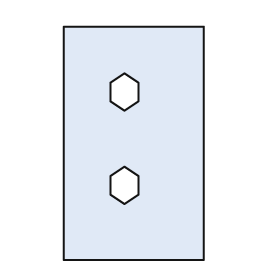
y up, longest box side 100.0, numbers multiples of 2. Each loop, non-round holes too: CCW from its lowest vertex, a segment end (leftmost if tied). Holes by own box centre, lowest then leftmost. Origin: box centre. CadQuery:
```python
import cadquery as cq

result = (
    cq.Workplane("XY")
    .moveTo(-30.0, -50.0)
    .lineTo(30.0, -50.0)
    .lineTo(30.0, 50.0)
    .lineTo(-30.0, 50.0)
    .close()
    .moveTo(-4.0, -26.0)
    .lineTo(2.0, -22.0)
    .lineTo(2.0, -14.0)
    .lineTo(-4.0, -10.0)
    .lineTo(-10.0, -14.0)
    .lineTo(-10.0, -22.0)
    .close()
    .moveTo(-4.0, 14.0)
    .lineTo(2.0, 18.0)
    .lineTo(2.0, 26.0)
    .lineTo(-4.0, 30.0)
    .lineTo(-10.0, 26.0)
    .lineTo(-10.0, 18.0)
    .close()
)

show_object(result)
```